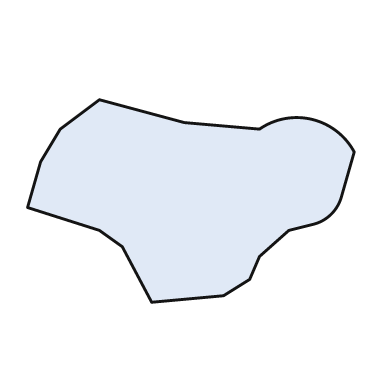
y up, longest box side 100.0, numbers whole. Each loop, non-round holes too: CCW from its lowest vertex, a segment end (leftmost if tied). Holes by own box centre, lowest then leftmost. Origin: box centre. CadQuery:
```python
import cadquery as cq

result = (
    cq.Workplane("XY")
    .moveTo(-12.0, -31.0)
    .lineTo(10.0, -29.0)
    .lineTo(18.0, -24.0)
    .lineTo(21.0, -17.0)
    .lineTo(30.0, -9.0)
    .lineTo(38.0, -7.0)
    .threePointArc((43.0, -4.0), (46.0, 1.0))
    .lineTo(50.0, 15.0)
    .threePointArc((37.0, 25.0), (21.0, 22.0))
    .lineTo(-2.0, 24.0)
    .lineTo(-28.0, 31.0)
    .lineTo(-40.0, 22.0)
    .lineTo(-46.0, 12.0)
    .lineTo(-50.0, -2.0)
    .lineTo(-28.0, -9.0)
    .lineTo(-21.0, -14.0)
    .close()
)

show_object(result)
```